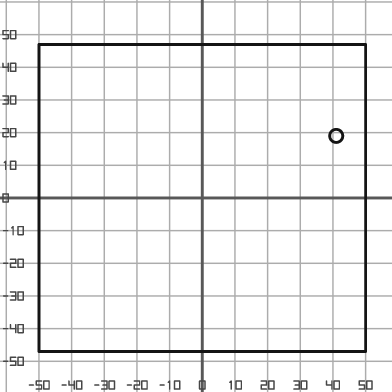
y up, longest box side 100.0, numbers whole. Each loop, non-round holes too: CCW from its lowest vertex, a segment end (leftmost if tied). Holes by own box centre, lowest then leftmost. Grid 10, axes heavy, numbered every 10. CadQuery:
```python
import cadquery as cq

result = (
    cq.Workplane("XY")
    .moveTo(-50.0, -47.0)
    .lineTo(50.0, -47.0)
    .lineTo(50.0, 47.0)
    .lineTo(-50.0, 47.0)
    .close()
    .moveTo(41.0, 19.0)
    .circle(2.0)
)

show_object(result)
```